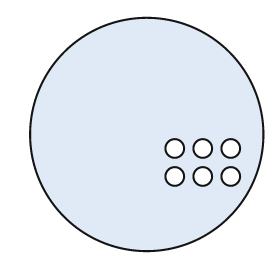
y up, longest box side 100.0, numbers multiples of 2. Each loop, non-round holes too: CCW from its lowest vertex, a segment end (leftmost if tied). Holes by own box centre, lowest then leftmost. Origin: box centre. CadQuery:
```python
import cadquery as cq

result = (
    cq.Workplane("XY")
    .moveTo(0.0, 0.0)
    .circle(50.0)
    .moveTo(12.0, -18.0)
    .circle(4.0)
    .moveTo(24.0, -18.0)
    .circle(4.0)
    .moveTo(36.0, -18.0)
    .circle(4.0)
    .moveTo(12.0, -6.0)
    .circle(4.0)
    .moveTo(24.0, -6.0)
    .circle(4.0)
    .moveTo(36.0, -6.0)
    .circle(4.0)
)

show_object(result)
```